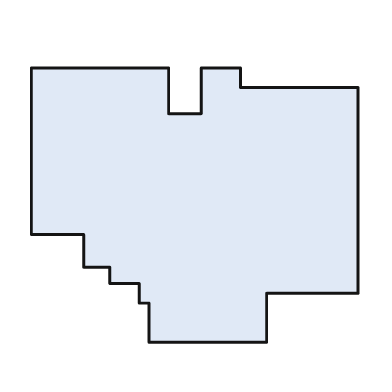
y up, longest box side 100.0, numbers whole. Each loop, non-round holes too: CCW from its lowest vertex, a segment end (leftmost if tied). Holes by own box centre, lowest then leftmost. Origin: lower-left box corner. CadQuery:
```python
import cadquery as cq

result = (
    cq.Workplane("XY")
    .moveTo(36.0, 0.0)
    .lineTo(72.0, 0.0)
    .lineTo(72.0, 15.0)
    .lineTo(100.0, 15.0)
    .lineTo(100.0, 78.0)
    .lineTo(64.0, 78.0)
    .lineTo(64.0, 84.0)
    .lineTo(52.0, 84.0)
    .lineTo(52.0, 70.0)
    .lineTo(42.0, 70.0)
    .lineTo(42.0, 84.0)
    .lineTo(0.0, 84.0)
    .lineTo(0.0, 33.0)
    .lineTo(16.0, 33.0)
    .lineTo(16.0, 23.0)
    .lineTo(24.0, 23.0)
    .lineTo(24.0, 18.0)
    .lineTo(33.0, 18.0)
    .lineTo(33.0, 12.0)
    .lineTo(36.0, 12.0)
    .close()
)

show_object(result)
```